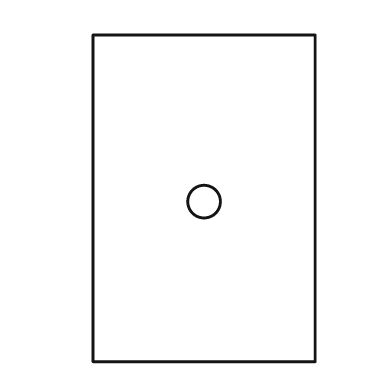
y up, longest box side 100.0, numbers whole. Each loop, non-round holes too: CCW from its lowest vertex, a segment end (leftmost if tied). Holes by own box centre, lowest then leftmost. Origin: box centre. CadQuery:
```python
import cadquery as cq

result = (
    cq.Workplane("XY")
    .moveTo(-34.0, -50.0)
    .lineTo(34.0, -50.0)
    .lineTo(34.0, 50.0)
    .lineTo(-34.0, 50.0)
    .close()
    .moveTo(0.0, -1.0)
    .circle(5.0)
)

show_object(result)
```